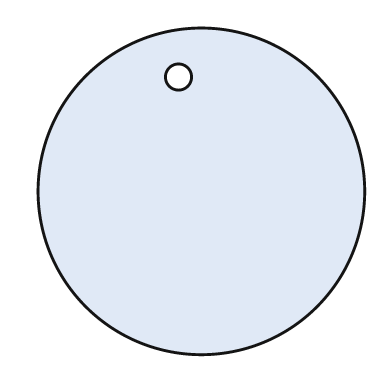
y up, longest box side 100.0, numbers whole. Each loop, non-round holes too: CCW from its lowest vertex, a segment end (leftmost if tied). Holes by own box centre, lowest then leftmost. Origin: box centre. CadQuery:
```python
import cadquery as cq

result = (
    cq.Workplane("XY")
    .moveTo(0.0, 0.0)
    .circle(50.0)
    .moveTo(-7.0, 35.0)
    .circle(4.0)
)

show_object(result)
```